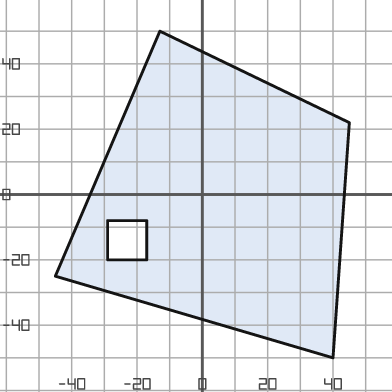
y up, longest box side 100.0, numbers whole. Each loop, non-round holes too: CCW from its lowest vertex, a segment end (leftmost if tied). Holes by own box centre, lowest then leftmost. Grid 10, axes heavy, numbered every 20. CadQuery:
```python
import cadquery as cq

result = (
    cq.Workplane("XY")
    .moveTo(40.0, -50.0)
    .lineTo(45.0, 22.0)
    .lineTo(-13.0, 50.0)
    .lineTo(-45.0, -25.0)
    .close()
    .moveTo(-29.0, -20.0)
    .lineTo(-17.0, -20.0)
    .lineTo(-17.0, -8.0)
    .lineTo(-29.0, -8.0)
    .close()
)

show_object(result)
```